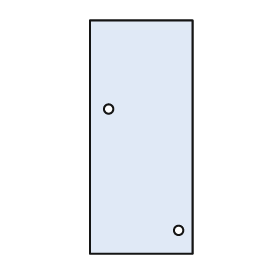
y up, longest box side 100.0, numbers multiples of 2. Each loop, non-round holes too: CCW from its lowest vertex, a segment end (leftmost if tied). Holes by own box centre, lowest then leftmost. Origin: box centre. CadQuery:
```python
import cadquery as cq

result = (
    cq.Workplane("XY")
    .moveTo(-22.0, -50.0)
    .lineTo(22.0, -50.0)
    .lineTo(22.0, 50.0)
    .lineTo(-22.0, 50.0)
    .close()
    .moveTo(16.0, -40.0)
    .circle(2.0)
    .moveTo(-14.0, 12.0)
    .circle(2.0)
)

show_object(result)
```